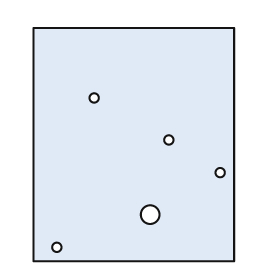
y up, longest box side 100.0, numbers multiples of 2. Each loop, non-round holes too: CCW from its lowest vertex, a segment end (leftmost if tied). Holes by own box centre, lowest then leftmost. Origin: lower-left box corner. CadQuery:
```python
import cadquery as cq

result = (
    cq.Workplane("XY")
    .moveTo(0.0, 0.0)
    .lineTo(86.0, 0.0)
    .lineTo(86.0, 100.0)
    .lineTo(0.0, 100.0)
    .close()
    .moveTo(10.0, 6.0)
    .circle(2.0)
    .moveTo(50.0, 20.0)
    .circle(4.0)
    .moveTo(80.0, 38.0)
    .circle(2.0)
    .moveTo(58.0, 52.0)
    .circle(2.0)
    .moveTo(26.0, 70.0)
    .circle(2.0)
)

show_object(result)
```